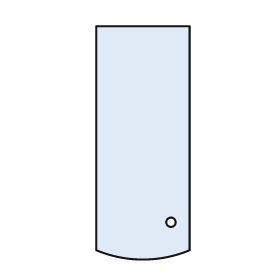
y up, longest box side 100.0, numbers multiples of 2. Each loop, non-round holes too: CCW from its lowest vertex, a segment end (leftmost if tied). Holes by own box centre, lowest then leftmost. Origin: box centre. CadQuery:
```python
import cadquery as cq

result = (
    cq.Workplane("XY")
    .moveTo(-20.0, -46.0)
    .threePointArc((0.0, -50.0), (20.0, -46.0))
    .lineTo(20.0, 50.0)
    .lineTo(-20.0, 50.0)
    .close()
    .moveTo(12.0, -34.0)
    .circle(2.0)
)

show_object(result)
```